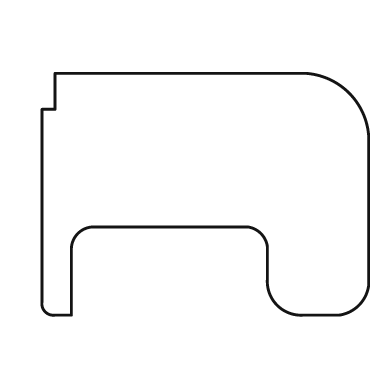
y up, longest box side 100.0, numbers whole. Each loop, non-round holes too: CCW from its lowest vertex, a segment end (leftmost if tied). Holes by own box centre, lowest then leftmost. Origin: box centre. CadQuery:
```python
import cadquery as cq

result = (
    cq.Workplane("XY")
    .moveTo(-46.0, -37.0)
    .lineTo(-41.0, -37.0)
    .lineTo(-41.0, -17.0)
    .threePointArc((-39.0, -12.0), (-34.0, -10.0))
    .lineTo(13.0, -10.0)
    .threePointArc((17.0, -12.0), (19.0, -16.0))
    .lineTo(19.0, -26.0)
    .threePointArc((22.0, -34.0), (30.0, -37.0))
    .lineTo(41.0, -37.0)
    .threePointArc((47.0, -34.0), (50.0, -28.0))
    .lineTo(50.0, 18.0)
    .threePointArc((44.0, 31.0), (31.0, 37.0))
    .lineTo(-46.0, 37.0)
    .lineTo(-46.0, 26.0)
    .lineTo(-50.0, 26.0)
    .lineTo(-50.0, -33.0)
    .threePointArc((-49.0, -36.0), (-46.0, -37.0))
    .close()
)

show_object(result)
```